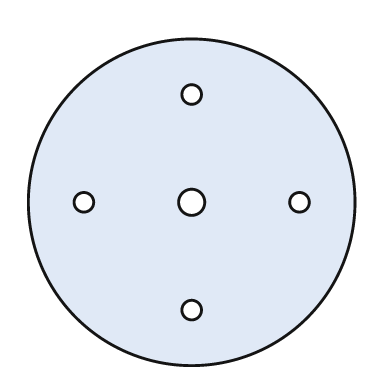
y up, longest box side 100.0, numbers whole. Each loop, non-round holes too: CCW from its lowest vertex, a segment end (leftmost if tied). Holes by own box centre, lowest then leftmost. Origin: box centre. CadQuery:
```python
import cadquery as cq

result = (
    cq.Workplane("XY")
    .moveTo(0.0, 0.0)
    .circle(50.0)
    .moveTo(0.0, -33.0)
    .circle(3.0)
    .moveTo(-33.0, 0.0)
    .circle(3.0)
    .moveTo(0.0, 0.0)
    .circle(4.0)
    .moveTo(33.0, 0.0)
    .circle(3.0)
    .moveTo(0.0, 33.0)
    .circle(3.0)
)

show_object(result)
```